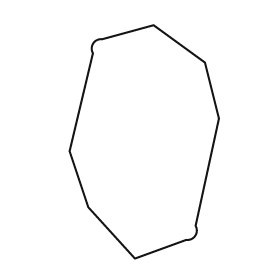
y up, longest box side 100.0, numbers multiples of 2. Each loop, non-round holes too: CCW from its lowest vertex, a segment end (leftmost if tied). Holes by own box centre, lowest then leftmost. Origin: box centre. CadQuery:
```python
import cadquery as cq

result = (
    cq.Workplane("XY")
    .moveTo(-4.0, -50.0)
    .lineTo(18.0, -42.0)
    .threePointArc((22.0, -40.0), (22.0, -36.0))
    .lineTo(32.0, 10.0)
    .lineTo(26.0, 34.0)
    .lineTo(4.0, 50.0)
    .lineTo(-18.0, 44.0)
    .threePointArc((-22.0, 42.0), (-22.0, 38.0))
    .lineTo(-32.0, -4.0)
    .lineTo(-24.0, -28.0)
    .close()
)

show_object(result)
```